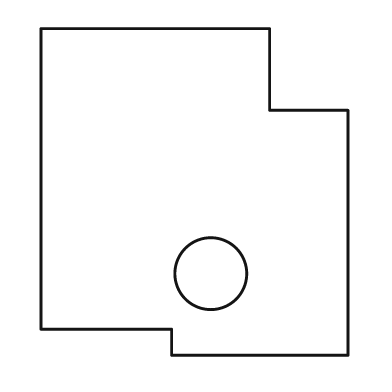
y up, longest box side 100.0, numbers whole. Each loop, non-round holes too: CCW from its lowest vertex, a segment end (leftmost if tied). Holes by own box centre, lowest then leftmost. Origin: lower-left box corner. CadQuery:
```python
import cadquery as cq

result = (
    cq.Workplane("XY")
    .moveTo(40.0, 0.0)
    .lineTo(94.0, 0.0)
    .lineTo(94.0, 75.0)
    .lineTo(70.0, 75.0)
    .lineTo(70.0, 100.0)
    .lineTo(0.0, 100.0)
    .lineTo(0.0, 8.0)
    .lineTo(40.0, 8.0)
    .close()
    .moveTo(52.0, 25.0)
    .circle(11.0)
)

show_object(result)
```